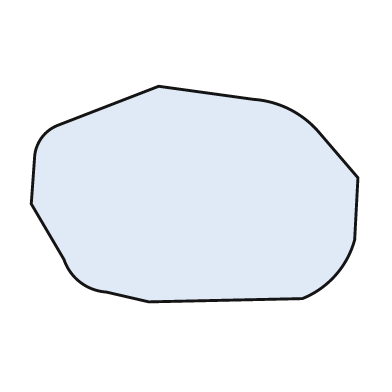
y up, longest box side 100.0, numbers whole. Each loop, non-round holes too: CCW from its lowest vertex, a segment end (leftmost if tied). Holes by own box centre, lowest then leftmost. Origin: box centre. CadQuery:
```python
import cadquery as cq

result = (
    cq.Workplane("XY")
    .moveTo(-14.0, -33.0)
    .lineTo(33.0, -32.0)
    .threePointArc((43.0, -25.0), (49.0, -14.0))
    .lineTo(50.0, 5.0)
    .lineTo(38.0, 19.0)
    .threePointArc((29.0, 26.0), (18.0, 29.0))
    .lineTo(-11.0, 33.0)
    .lineTo(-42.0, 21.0)
    .threePointArc((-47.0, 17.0), (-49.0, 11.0))
    .lineTo(-50.0, -3.0)
    .lineTo(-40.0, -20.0)
    .threePointArc((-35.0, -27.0), (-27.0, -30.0))
    .close()
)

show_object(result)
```